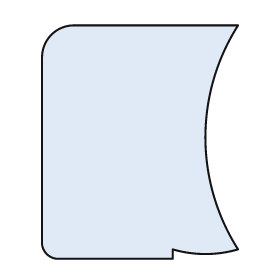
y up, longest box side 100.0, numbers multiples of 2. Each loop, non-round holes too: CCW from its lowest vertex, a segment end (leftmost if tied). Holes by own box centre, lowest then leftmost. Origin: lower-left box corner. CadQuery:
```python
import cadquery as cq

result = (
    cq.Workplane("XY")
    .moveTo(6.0, 0.0)
    .lineTo(56.0, 0.0)
    .lineTo(56.0, 4.0)
    .threePointArc((70.0, 2.0), (84.0, 4.0))
    .threePointArc((70.0, 52.0), (84.0, 100.0))
    .lineTo(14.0, 100.0)
    .threePointArc((4.0, 96.0), (0.0, 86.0))
    .lineTo(0.0, 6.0)
    .threePointArc((2.0, 2.0), (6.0, 0.0))
    .close()
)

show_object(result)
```